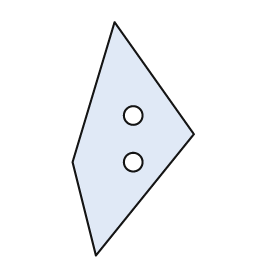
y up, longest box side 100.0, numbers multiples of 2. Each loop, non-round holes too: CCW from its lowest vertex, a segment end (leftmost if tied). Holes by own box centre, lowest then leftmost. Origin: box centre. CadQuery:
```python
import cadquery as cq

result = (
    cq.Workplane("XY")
    .moveTo(-16.0, -50.0)
    .lineTo(26.0, 2.0)
    .lineTo(-8.0, 50.0)
    .lineTo(-26.0, -10.0)
    .close()
    .moveTo(0.0, -10.0)
    .circle(4.0)
    .moveTo(0.0, 10.0)
    .circle(4.0)
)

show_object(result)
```